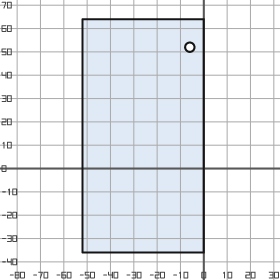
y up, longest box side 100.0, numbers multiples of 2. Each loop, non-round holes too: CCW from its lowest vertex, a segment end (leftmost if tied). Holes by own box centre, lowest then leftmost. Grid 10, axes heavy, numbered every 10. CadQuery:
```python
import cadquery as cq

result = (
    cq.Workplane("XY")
    .moveTo(-52.0, -36.0)
    .lineTo(0.0, -36.0)
    .lineTo(0.0, 64.0)
    .lineTo(-52.0, 64.0)
    .close()
    .moveTo(-6.0, 52.0)
    .circle(2.0)
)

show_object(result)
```